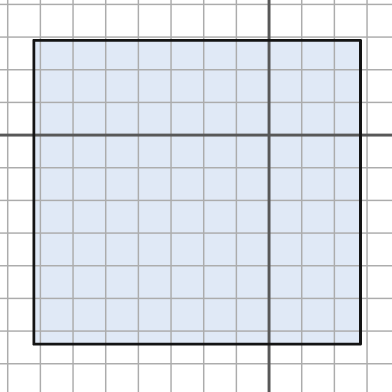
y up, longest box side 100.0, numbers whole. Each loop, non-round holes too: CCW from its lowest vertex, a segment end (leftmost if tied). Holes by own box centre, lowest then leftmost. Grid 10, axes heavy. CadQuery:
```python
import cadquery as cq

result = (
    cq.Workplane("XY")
    .moveTo(-72.0, -64.0)
    .lineTo(28.0, -64.0)
    .lineTo(28.0, 29.0)
    .lineTo(-72.0, 29.0)
    .close()
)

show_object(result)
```